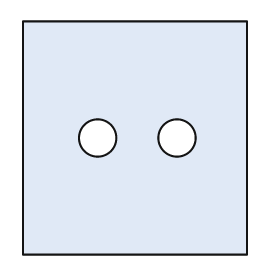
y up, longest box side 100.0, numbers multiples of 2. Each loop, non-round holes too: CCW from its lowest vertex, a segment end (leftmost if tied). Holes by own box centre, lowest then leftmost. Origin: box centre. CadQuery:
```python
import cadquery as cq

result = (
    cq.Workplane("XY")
    .moveTo(-48.0, -50.0)
    .lineTo(48.0, -50.0)
    .lineTo(48.0, 50.0)
    .lineTo(-48.0, 50.0)
    .close()
    .moveTo(-16.0, 0.0)
    .circle(8.0)
    .moveTo(18.0, 0.0)
    .circle(8.0)
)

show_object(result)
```